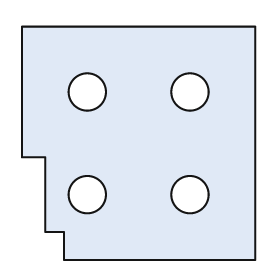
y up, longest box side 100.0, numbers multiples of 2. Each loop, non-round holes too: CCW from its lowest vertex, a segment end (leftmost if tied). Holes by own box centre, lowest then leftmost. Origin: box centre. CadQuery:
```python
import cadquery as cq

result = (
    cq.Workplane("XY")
    .moveTo(-32.0, -50.0)
    .lineTo(50.0, -50.0)
    .lineTo(50.0, 50.0)
    .lineTo(-50.0, 50.0)
    .lineTo(-50.0, -6.0)
    .lineTo(-40.0, -6.0)
    .lineTo(-40.0, -38.0)
    .lineTo(-32.0, -38.0)
    .close()
    .moveTo(-22.0, -22.0)
    .circle(8.0)
    .moveTo(22.0, -22.0)
    .circle(8.0)
    .moveTo(-22.0, 22.0)
    .circle(8.0)
    .moveTo(22.0, 22.0)
    .circle(8.0)
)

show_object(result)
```